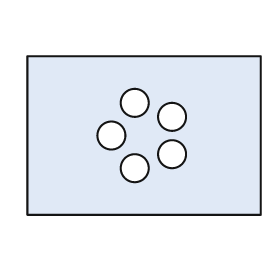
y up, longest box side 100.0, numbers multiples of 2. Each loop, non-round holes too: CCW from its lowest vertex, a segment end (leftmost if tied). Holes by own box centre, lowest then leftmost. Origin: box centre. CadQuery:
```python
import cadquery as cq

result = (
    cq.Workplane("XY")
    .moveTo(-50.0, -34.0)
    .lineTo(50.0, -34.0)
    .lineTo(50.0, 34.0)
    .lineTo(-50.0, 34.0)
    .close()
    .moveTo(-4.0, -14.0)
    .circle(6.0)
    .moveTo(12.0, -8.0)
    .circle(6.0)
    .moveTo(-14.0, 0.0)
    .circle(6.0)
    .moveTo(12.0, 8.0)
    .circle(6.0)
    .moveTo(-4.0, 14.0)
    .circle(6.0)
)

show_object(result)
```